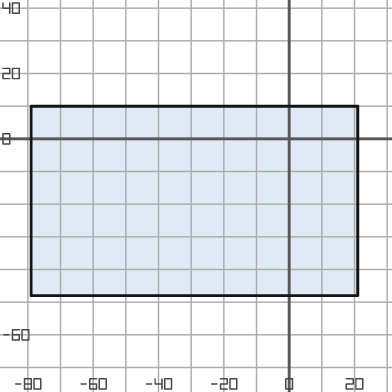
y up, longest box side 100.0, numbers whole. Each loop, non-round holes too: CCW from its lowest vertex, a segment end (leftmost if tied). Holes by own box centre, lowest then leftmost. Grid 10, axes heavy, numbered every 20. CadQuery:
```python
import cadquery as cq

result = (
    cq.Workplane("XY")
    .moveTo(-79.0, -48.0)
    .lineTo(21.0, -48.0)
    .lineTo(21.0, 10.0)
    .lineTo(-79.0, 10.0)
    .close()
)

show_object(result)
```